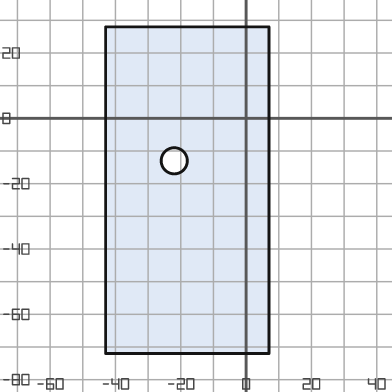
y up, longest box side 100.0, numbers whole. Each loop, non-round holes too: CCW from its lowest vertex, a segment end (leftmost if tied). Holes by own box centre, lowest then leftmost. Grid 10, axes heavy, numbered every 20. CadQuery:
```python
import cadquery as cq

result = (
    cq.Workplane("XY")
    .moveTo(-43.0, -72.0)
    .lineTo(7.0, -72.0)
    .lineTo(7.0, 28.0)
    .lineTo(-43.0, 28.0)
    .close()
    .moveTo(-22.0, -13.0)
    .circle(4.0)
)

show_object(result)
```